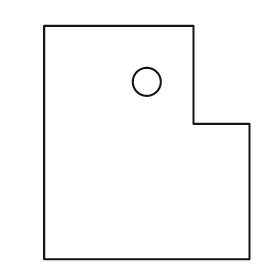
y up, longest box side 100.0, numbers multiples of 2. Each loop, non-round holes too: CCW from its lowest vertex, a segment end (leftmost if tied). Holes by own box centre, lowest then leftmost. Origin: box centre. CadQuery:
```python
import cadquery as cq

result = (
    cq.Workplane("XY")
    .moveTo(-44.0, -50.0)
    .lineTo(44.0, -50.0)
    .lineTo(44.0, 8.0)
    .lineTo(20.0, 8.0)
    .lineTo(20.0, 50.0)
    .lineTo(-44.0, 50.0)
    .close()
    .moveTo(0.0, 26.0)
    .circle(6.0)
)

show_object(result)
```